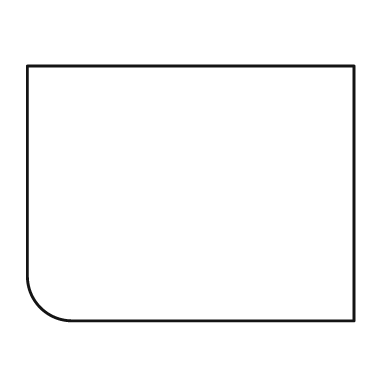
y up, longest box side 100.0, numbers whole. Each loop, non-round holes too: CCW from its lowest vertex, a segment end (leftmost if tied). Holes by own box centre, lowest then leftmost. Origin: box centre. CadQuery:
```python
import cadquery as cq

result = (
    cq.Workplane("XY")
    .moveTo(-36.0, -39.0)
    .lineTo(50.0, -39.0)
    .lineTo(50.0, 39.0)
    .lineTo(-50.0, 39.0)
    .lineTo(-50.0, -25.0)
    .threePointArc((-46.0, -35.0), (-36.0, -39.0))
    .close()
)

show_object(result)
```